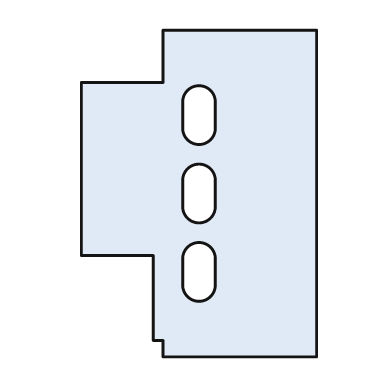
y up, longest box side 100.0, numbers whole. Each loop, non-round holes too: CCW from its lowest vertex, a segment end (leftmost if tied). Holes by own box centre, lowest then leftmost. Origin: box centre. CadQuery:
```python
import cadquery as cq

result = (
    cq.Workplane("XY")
    .moveTo(-11.0, -50.0)
    .lineTo(36.0, -50.0)
    .lineTo(36.0, 50.0)
    .lineTo(-11.0, 50.0)
    .lineTo(-11.0, 34.0)
    .lineTo(-36.0, 34.0)
    .lineTo(-36.0, -19.0)
    .lineTo(-14.0, -19.0)
    .lineTo(-14.0, -45.0)
    .lineTo(-11.0, -45.0)
    .close()
    .moveTo(-5.0, -28.0)
    .threePointArc((0.0, -33.0), (5.0, -28.0))
    .lineTo(5.0, -20.0)
    .threePointArc((0.0, -15.0), (-5.0, -20.0))
    .close()
    .moveTo(-5.0, -4.0)
    .threePointArc((0.0, -9.0), (5.0, -4.0))
    .lineTo(5.0, 4.0)
    .threePointArc((0.0, 9.0), (-5.0, 4.0))
    .close()
    .moveTo(-5.0, 20.0)
    .threePointArc((0.0, 15.0), (5.0, 20.0))
    .lineTo(5.0, 28.0)
    .threePointArc((0.0, 33.0), (-5.0, 28.0))
    .close()
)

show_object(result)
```